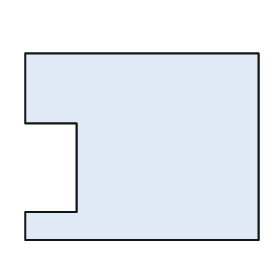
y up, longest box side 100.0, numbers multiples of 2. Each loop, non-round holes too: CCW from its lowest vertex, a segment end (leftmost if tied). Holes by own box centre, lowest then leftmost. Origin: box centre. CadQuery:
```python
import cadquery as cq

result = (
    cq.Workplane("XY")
    .moveTo(-50.0, -40.0)
    .lineTo(50.0, -40.0)
    .lineTo(50.0, 40.0)
    .lineTo(-50.0, 40.0)
    .lineTo(-50.0, 10.0)
    .lineTo(-28.0, 10.0)
    .lineTo(-28.0, -28.0)
    .lineTo(-50.0, -28.0)
    .close()
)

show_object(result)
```